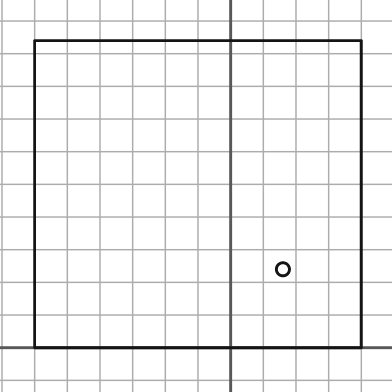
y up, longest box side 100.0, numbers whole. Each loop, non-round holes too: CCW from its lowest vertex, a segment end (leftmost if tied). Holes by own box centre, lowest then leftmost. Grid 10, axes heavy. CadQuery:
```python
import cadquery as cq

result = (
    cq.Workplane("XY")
    .moveTo(-60.0, 0.0)
    .lineTo(40.0, 0.0)
    .lineTo(40.0, 94.0)
    .lineTo(-60.0, 94.0)
    .close()
    .moveTo(16.0, 24.0)
    .circle(2.0)
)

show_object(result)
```